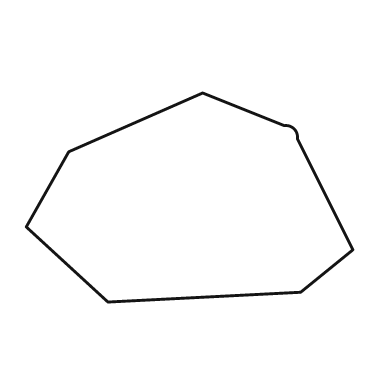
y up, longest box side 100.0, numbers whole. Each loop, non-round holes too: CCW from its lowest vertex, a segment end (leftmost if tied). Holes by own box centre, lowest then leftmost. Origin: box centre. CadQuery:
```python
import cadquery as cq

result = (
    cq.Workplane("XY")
    .moveTo(-25.0, -32.0)
    .lineTo(34.0, -29.0)
    .lineTo(50.0, -16.0)
    .lineTo(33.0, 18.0)
    .threePointArc((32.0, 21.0), (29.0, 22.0))
    .lineTo(4.0, 32.0)
    .lineTo(-37.0, 14.0)
    .lineTo(-50.0, -9.0)
    .close()
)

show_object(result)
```